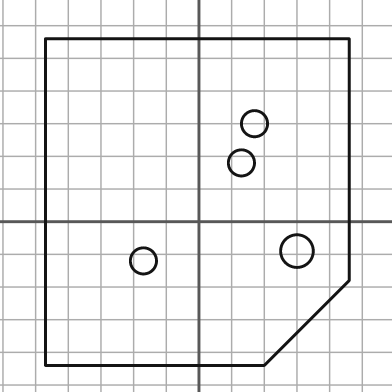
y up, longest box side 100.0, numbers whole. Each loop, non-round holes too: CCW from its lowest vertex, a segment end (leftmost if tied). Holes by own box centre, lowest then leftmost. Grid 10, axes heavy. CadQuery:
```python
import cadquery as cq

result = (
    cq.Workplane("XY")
    .moveTo(-47.0, -44.0)
    .lineTo(20.0, -44.0)
    .lineTo(46.0, -18.0)
    .lineTo(46.0, 56.0)
    .lineTo(-47.0, 56.0)
    .close()
    .moveTo(-17.0, -12.0)
    .circle(4.0)
    .moveTo(30.0, -9.0)
    .circle(5.0)
    .moveTo(13.0, 18.0)
    .circle(4.0)
    .moveTo(17.0, 30.0)
    .circle(4.0)
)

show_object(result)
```